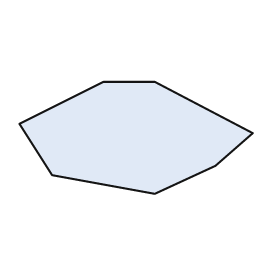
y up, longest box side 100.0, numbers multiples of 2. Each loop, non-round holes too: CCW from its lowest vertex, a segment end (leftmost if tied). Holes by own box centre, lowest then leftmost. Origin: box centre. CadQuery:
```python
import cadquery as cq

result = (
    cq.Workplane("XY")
    .moveTo(8.0, -24.0)
    .lineTo(34.0, -12.0)
    .lineTo(50.0, 2.0)
    .lineTo(8.0, 24.0)
    .lineTo(-14.0, 24.0)
    .lineTo(-50.0, 6.0)
    .lineTo(-36.0, -16.0)
    .close()
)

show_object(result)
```